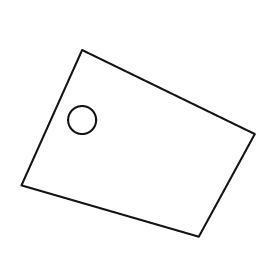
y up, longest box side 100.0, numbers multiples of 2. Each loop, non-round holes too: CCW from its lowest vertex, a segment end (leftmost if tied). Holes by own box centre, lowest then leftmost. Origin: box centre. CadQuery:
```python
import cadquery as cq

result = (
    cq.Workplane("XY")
    .moveTo(26.0, -40.0)
    .lineTo(50.0, 4.0)
    .lineTo(-24.0, 40.0)
    .lineTo(-50.0, -18.0)
    .close()
    .moveTo(-24.0, 10.0)
    .circle(6.0)
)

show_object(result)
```